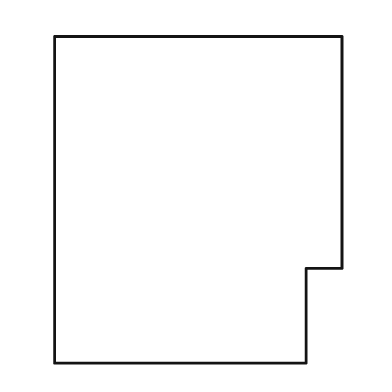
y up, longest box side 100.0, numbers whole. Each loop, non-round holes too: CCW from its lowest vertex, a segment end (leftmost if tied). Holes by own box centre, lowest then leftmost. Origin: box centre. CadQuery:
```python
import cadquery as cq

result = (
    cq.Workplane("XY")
    .moveTo(-44.0, -50.0)
    .lineTo(33.0, -50.0)
    .lineTo(33.0, -21.0)
    .lineTo(44.0, -21.0)
    .lineTo(44.0, 50.0)
    .lineTo(-44.0, 50.0)
    .close()
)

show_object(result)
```